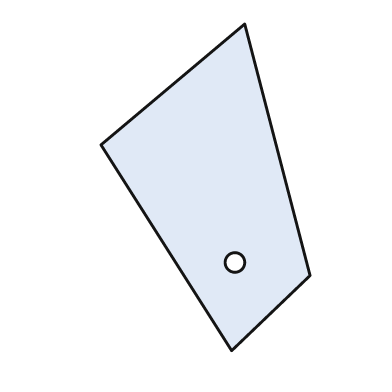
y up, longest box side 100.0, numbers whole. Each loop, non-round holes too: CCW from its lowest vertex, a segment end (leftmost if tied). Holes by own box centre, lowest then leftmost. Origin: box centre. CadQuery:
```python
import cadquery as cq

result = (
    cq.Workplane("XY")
    .moveTo(8.0, -50.0)
    .lineTo(32.0, -27.0)
    .lineTo(12.0, 50.0)
    .lineTo(-32.0, 13.0)
    .close()
    .moveTo(9.0, -23.0)
    .circle(3.0)
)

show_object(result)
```